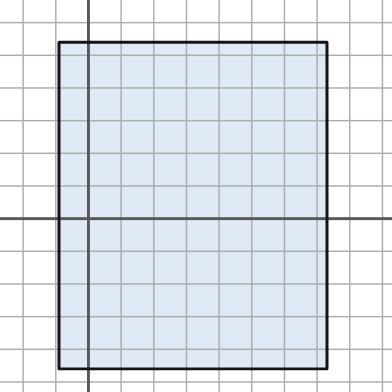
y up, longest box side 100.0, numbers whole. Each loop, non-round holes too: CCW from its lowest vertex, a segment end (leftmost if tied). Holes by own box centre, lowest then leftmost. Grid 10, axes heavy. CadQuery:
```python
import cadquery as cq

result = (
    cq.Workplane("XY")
    .moveTo(-9.0, -46.0)
    .lineTo(73.0, -46.0)
    .lineTo(73.0, 54.0)
    .lineTo(-9.0, 54.0)
    .close()
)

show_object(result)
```